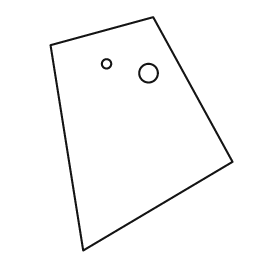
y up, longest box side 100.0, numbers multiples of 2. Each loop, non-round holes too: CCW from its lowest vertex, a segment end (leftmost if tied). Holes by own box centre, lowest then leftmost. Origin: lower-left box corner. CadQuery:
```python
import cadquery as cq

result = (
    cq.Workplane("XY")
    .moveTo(14.0, 0.0)
    .lineTo(78.0, 38.0)
    .lineTo(44.0, 100.0)
    .lineTo(0.0, 88.0)
    .close()
    .moveTo(42.0, 76.0)
    .circle(4.0)
    .moveTo(24.0, 80.0)
    .circle(2.0)
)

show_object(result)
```